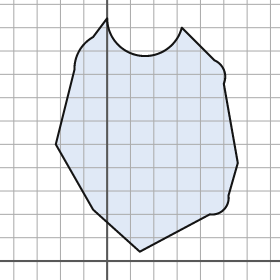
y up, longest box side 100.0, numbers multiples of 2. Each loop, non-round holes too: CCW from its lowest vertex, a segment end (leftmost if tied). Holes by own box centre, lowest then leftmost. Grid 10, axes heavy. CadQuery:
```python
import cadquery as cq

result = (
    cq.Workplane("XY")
    .moveTo(14.0, 4.0)
    .lineTo(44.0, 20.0)
    .threePointArc((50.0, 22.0), (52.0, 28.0))
    .lineTo(56.0, 42.0)
    .lineTo(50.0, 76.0)
    .threePointArc((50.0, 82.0), (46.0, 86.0))
    .lineTo(32.0, 100.0)
    .threePointArc((14.0, 88.0), (0.0, 104.0))
    .lineTo(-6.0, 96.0)
    .threePointArc((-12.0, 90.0), (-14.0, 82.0))
    .lineTo(-22.0, 50.0)
    .lineTo(-6.0, 22.0)
    .close()
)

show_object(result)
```